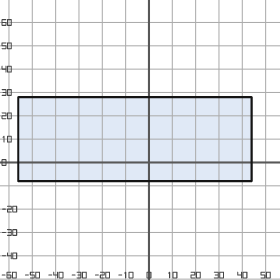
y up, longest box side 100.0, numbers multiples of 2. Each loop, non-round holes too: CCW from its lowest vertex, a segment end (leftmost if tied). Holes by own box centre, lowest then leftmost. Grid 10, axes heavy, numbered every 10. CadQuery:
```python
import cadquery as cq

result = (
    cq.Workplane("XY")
    .moveTo(-56.0, -8.0)
    .lineTo(44.0, -8.0)
    .lineTo(44.0, 28.0)
    .lineTo(-56.0, 28.0)
    .close()
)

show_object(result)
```